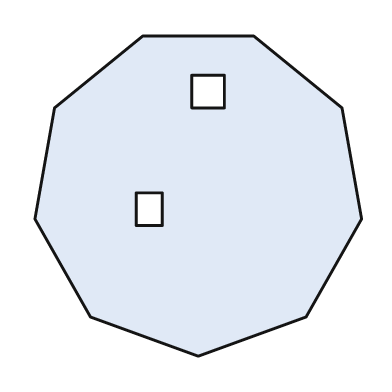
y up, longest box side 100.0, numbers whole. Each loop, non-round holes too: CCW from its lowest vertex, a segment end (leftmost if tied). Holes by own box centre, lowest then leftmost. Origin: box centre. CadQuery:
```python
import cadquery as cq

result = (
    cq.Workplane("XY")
    .moveTo(0.0, -49.0)
    .lineTo(33.0, -37.0)
    .lineTo(50.0, -7.0)
    .lineTo(44.0, 27.0)
    .lineTo(17.0, 49.0)
    .lineTo(-17.0, 49.0)
    .lineTo(-44.0, 27.0)
    .lineTo(-50.0, -7.0)
    .lineTo(-33.0, -37.0)
    .close()
    .moveTo(-19.0, -9.0)
    .lineTo(-11.0, -9.0)
    .lineTo(-11.0, 1.0)
    .lineTo(-19.0, 1.0)
    .close()
    .moveTo(-2.0, 27.0)
    .lineTo(8.0, 27.0)
    .lineTo(8.0, 37.0)
    .lineTo(-2.0, 37.0)
    .close()
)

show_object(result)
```